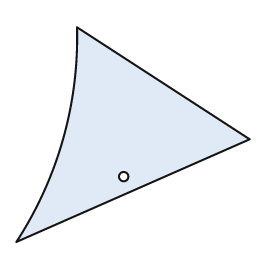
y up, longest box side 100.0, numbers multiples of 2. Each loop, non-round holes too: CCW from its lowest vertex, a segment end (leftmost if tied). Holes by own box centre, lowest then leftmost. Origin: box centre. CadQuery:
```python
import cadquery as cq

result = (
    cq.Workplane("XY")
    .moveTo(-50.0, -46.0)
    .lineTo(50.0, -2.0)
    .lineTo(-24.0, 46.0)
    .threePointArc((-30.0, -2.0), (-50.0, -46.0))
    .close()
    .moveTo(-4.0, -18.0)
    .circle(2.0)
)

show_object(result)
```